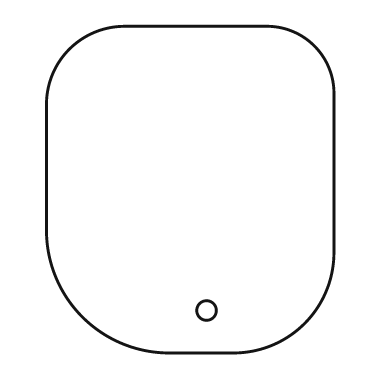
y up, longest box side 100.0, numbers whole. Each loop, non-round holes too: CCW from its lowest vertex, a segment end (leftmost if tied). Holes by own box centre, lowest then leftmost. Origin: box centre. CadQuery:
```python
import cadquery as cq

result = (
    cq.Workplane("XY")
    .moveTo(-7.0, -50.0)
    .lineTo(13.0, -50.0)
    .threePointArc((35.0, -41.0), (44.0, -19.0))
    .lineTo(44.0, 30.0)
    .threePointArc((38.0, 44.0), (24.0, 50.0))
    .lineTo(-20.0, 50.0)
    .threePointArc((-37.0, 43.0), (-44.0, 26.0))
    .lineTo(-44.0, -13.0)
    .threePointArc((-33.0, -39.0), (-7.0, -50.0))
    .close()
    .moveTo(5.0, -37.0)
    .circle(3.0)
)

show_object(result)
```